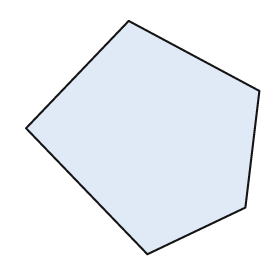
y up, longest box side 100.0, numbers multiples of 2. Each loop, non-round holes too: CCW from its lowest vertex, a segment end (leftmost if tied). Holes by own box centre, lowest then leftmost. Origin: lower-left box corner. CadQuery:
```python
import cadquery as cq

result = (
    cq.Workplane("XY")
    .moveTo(52.0, 0.0)
    .lineTo(94.0, 20.0)
    .lineTo(100.0, 70.0)
    .lineTo(44.0, 100.0)
    .lineTo(0.0, 54.0)
    .close()
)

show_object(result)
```